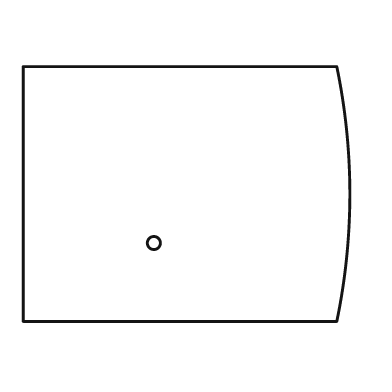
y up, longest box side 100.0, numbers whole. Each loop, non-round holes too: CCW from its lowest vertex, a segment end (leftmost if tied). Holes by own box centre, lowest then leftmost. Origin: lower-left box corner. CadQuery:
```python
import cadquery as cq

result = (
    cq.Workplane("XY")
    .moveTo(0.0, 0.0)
    .lineTo(96.0, 0.0)
    .threePointArc((100.0, 39.0), (96.0, 78.0))
    .lineTo(0.0, 78.0)
    .close()
    .moveTo(40.0, 24.0)
    .circle(2.0)
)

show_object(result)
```